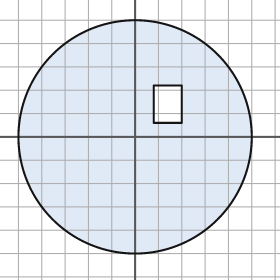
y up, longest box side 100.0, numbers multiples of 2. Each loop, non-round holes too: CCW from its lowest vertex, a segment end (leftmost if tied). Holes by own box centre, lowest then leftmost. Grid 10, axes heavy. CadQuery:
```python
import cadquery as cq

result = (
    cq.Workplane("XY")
    .moveTo(0.0, 0.0)
    .circle(50.0)
    .moveTo(8.0, 6.0)
    .lineTo(20.0, 6.0)
    .lineTo(20.0, 22.0)
    .lineTo(8.0, 22.0)
    .close()
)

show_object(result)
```